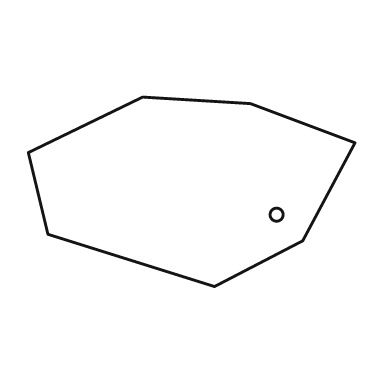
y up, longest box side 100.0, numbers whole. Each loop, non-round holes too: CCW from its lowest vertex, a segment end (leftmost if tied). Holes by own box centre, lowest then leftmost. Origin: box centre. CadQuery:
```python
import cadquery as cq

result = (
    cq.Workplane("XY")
    .moveTo(7.0, -29.0)
    .lineTo(34.0, -15.0)
    .lineTo(50.0, 15.0)
    .lineTo(18.0, 27.0)
    .lineTo(-15.0, 29.0)
    .lineTo(-50.0, 12.0)
    .lineTo(-44.0, -13.0)
    .close()
    .moveTo(26.0, -7.0)
    .circle(2.0)
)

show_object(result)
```